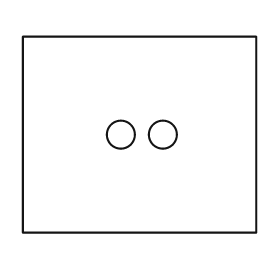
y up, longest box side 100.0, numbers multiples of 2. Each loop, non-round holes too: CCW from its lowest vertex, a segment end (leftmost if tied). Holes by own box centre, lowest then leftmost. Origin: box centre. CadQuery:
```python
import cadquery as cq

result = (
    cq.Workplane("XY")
    .moveTo(-50.0, -42.0)
    .lineTo(50.0, -42.0)
    .lineTo(50.0, 42.0)
    .lineTo(-50.0, 42.0)
    .close()
    .moveTo(-8.0, 0.0)
    .circle(6.0)
    .moveTo(10.0, 0.0)
    .circle(6.0)
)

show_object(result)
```